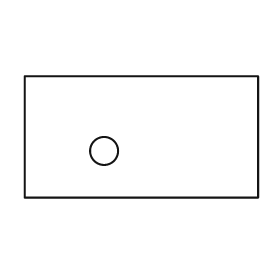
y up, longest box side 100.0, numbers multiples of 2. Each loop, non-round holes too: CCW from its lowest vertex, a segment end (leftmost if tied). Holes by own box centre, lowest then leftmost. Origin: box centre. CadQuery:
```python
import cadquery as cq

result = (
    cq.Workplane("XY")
    .moveTo(-50.0, -26.0)
    .lineTo(50.0, -26.0)
    .lineTo(50.0, 26.0)
    .lineTo(-50.0, 26.0)
    .close()
    .moveTo(-16.0, -6.0)
    .circle(6.0)
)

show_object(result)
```